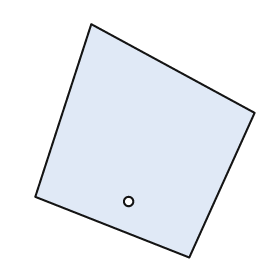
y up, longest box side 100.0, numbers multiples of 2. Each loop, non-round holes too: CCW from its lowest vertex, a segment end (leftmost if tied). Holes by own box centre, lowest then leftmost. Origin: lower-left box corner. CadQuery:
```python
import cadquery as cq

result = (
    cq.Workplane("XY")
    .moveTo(66.0, 0.0)
    .lineTo(94.0, 62.0)
    .lineTo(24.0, 100.0)
    .lineTo(0.0, 26.0)
    .close()
    .moveTo(40.0, 24.0)
    .circle(2.0)
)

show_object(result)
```